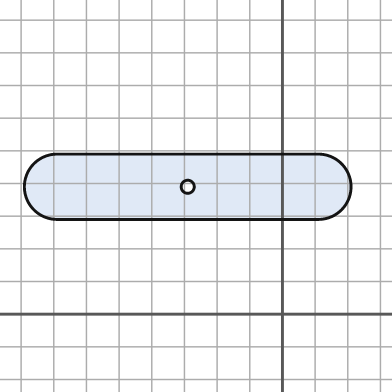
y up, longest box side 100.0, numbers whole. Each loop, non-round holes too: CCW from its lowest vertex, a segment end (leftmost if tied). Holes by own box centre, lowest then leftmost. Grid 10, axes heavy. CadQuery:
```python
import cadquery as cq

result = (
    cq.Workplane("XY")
    .moveTo(-69.0, 29.0)
    .lineTo(11.0, 29.0)
    .threePointArc((21.0, 39.0), (11.0, 49.0))
    .lineTo(-69.0, 49.0)
    .threePointArc((-79.0, 39.0), (-69.0, 29.0))
    .close()
    .moveTo(-29.0, 39.0)
    .circle(2.0)
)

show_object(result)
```